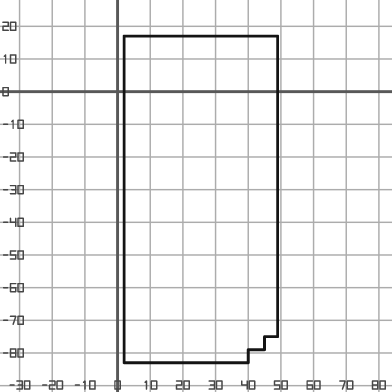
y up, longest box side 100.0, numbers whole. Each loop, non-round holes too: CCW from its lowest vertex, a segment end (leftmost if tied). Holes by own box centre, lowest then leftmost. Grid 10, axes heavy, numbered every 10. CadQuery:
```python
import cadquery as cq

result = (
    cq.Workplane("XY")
    .moveTo(2.0, -83.0)
    .lineTo(40.0, -83.0)
    .lineTo(40.0, -79.0)
    .lineTo(45.0, -79.0)
    .lineTo(45.0, -75.0)
    .lineTo(49.0, -75.0)
    .lineTo(49.0, 17.0)
    .lineTo(2.0, 17.0)
    .close()
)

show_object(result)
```